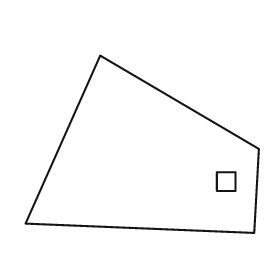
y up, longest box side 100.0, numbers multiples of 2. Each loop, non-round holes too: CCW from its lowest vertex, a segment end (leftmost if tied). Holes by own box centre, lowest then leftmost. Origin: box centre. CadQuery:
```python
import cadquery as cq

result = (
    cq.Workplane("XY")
    .moveTo(48.0, -38.0)
    .lineTo(50.0, -2.0)
    .lineTo(-18.0, 38.0)
    .lineTo(-50.0, -34.0)
    .close()
    .moveTo(32.0, -20.0)
    .lineTo(40.0, -20.0)
    .lineTo(40.0, -12.0)
    .lineTo(32.0, -12.0)
    .close()
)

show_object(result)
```